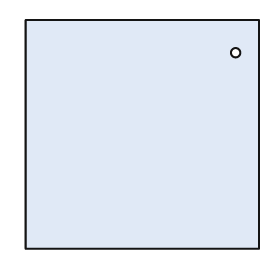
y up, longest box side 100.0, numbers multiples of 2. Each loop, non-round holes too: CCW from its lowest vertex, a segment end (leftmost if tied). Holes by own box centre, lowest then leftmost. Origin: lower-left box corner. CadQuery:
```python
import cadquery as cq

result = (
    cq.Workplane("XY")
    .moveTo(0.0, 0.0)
    .lineTo(100.0, 0.0)
    .lineTo(100.0, 98.0)
    .lineTo(0.0, 98.0)
    .close()
    .moveTo(90.0, 84.0)
    .circle(2.0)
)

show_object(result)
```